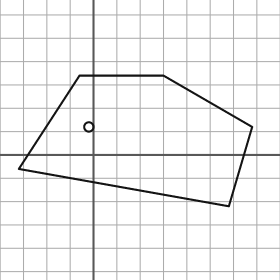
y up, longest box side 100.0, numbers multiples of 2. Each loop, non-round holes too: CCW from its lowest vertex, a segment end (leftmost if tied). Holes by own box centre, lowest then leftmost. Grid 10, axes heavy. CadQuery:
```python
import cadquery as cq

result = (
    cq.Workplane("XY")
    .moveTo(58.0, -22.0)
    .lineTo(68.0, 12.0)
    .lineTo(30.0, 34.0)
    .lineTo(-6.0, 34.0)
    .lineTo(-32.0, -6.0)
    .close()
    .moveTo(-2.0, 12.0)
    .circle(2.0)
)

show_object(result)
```